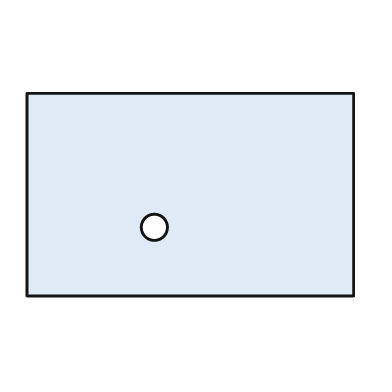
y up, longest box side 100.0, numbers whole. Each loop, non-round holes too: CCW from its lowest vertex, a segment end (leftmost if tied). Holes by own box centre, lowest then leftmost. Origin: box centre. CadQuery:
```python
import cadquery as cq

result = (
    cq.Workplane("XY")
    .moveTo(-50.0, -31.0)
    .lineTo(50.0, -31.0)
    .lineTo(50.0, 31.0)
    .lineTo(-50.0, 31.0)
    .close()
    .moveTo(-11.0, -10.0)
    .circle(4.0)
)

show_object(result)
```